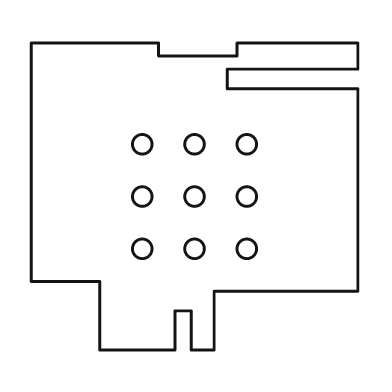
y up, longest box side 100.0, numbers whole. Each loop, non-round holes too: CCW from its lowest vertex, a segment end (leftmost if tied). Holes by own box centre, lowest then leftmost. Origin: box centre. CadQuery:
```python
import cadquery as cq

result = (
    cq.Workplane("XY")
    .moveTo(-29.0, -47.0)
    .lineTo(-6.0, -47.0)
    .lineTo(-6.0, -35.0)
    .lineTo(-1.0, -35.0)
    .lineTo(-1.0, -47.0)
    .lineTo(6.0, -47.0)
    .lineTo(6.0, -29.0)
    .lineTo(50.0, -29.0)
    .lineTo(50.0, 33.0)
    .lineTo(10.0, 33.0)
    .lineTo(10.0, 39.0)
    .lineTo(50.0, 39.0)
    .lineTo(50.0, 47.0)
    .lineTo(13.0, 47.0)
    .lineTo(13.0, 43.0)
    .lineTo(-11.0, 43.0)
    .lineTo(-11.0, 47.0)
    .lineTo(-50.0, 47.0)
    .lineTo(-50.0, -26.0)
    .lineTo(-29.0, -26.0)
    .close()
    .moveTo(-16.0, -16.0)
    .circle(3.0)
    .moveTo(0.0, -16.0)
    .circle(3.0)
    .moveTo(16.0, -16.0)
    .circle(3.0)
    .moveTo(-16.0, 0.0)
    .circle(3.0)
    .moveTo(0.0, 0.0)
    .circle(3.0)
    .moveTo(16.0, 0.0)
    .circle(3.0)
    .moveTo(-16.0, 16.0)
    .circle(3.0)
    .moveTo(0.0, 16.0)
    .circle(3.0)
    .moveTo(16.0, 16.0)
    .circle(3.0)
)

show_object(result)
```